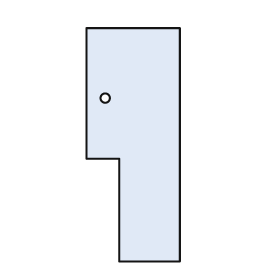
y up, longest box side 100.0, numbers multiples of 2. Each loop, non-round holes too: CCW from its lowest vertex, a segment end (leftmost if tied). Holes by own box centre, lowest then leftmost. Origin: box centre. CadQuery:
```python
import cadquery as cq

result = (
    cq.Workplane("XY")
    .moveTo(-6.0, -50.0)
    .lineTo(20.0, -50.0)
    .lineTo(20.0, 50.0)
    .lineTo(-20.0, 50.0)
    .lineTo(-20.0, -6.0)
    .lineTo(-6.0, -6.0)
    .close()
    .moveTo(-12.0, 20.0)
    .circle(2.0)
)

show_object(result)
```